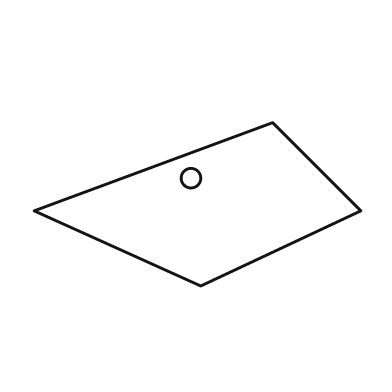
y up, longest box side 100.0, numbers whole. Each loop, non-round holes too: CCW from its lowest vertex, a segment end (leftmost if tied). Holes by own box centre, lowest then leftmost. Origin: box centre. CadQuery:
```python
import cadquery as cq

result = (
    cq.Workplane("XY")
    .moveTo(1.0, -25.0)
    .lineTo(50.0, -2.0)
    .lineTo(23.0, 25.0)
    .lineTo(-50.0, -2.0)
    .close()
    .moveTo(-2.0, 8.0)
    .circle(3.0)
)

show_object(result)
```